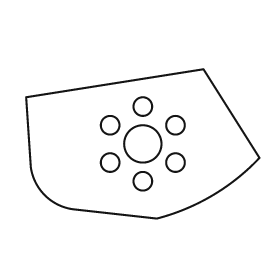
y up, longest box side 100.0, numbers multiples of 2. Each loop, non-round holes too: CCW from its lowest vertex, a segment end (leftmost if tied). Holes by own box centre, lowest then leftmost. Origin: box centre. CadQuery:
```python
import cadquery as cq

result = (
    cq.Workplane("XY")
    .moveTo(6.0, -32.0)
    .threePointArc((30.0, -22.0), (50.0, -6.0))
    .lineTo(26.0, 32.0)
    .lineTo(-50.0, 20.0)
    .lineTo(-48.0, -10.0)
    .threePointArc((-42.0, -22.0), (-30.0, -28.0))
    .close()
    .moveTo(0.0, -16.0)
    .circle(4.0)
    .moveTo(-14.0, -8.0)
    .circle(4.0)
    .moveTo(14.0, -8.0)
    .circle(4.0)
    .moveTo(0.0, 0.0)
    .circle(8.0)
    .moveTo(-14.0, 8.0)
    .circle(4.0)
    .moveTo(14.0, 8.0)
    .circle(4.0)
    .moveTo(0.0, 16.0)
    .circle(4.0)
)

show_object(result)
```